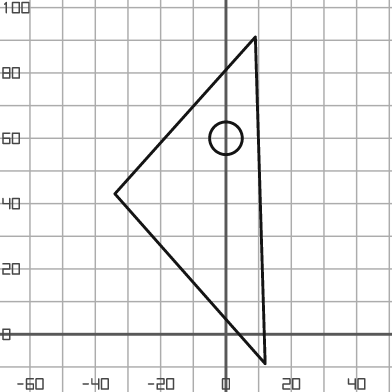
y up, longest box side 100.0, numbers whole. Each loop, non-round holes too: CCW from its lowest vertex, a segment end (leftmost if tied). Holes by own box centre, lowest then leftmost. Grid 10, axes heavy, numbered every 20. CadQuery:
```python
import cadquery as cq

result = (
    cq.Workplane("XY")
    .moveTo(12.0, -9.0)
    .lineTo(9.0, 91.0)
    .lineTo(-34.0, 43.0)
    .close()
    .moveTo(0.0, 60.0)
    .circle(5.0)
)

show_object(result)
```